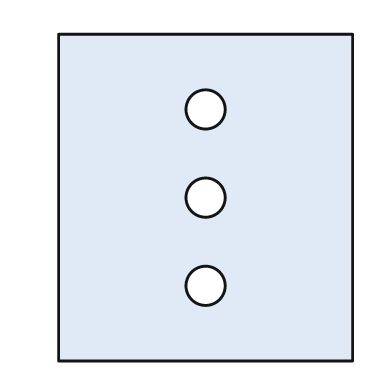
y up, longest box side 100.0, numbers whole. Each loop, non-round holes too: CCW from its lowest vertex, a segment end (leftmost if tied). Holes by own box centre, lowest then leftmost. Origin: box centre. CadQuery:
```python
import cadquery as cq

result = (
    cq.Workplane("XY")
    .moveTo(-45.0, -50.0)
    .lineTo(45.0, -50.0)
    .lineTo(45.0, 50.0)
    .lineTo(-45.0, 50.0)
    .close()
    .moveTo(0.0, -27.0)
    .circle(6.0)
    .moveTo(0.0, 0.0)
    .circle(6.0)
    .moveTo(0.0, 27.0)
    .circle(6.0)
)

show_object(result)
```